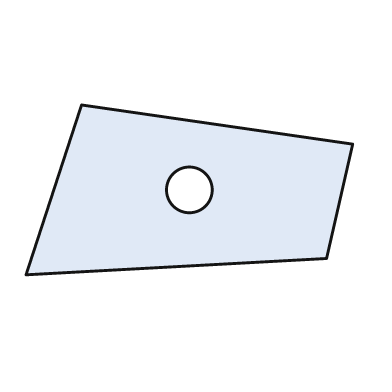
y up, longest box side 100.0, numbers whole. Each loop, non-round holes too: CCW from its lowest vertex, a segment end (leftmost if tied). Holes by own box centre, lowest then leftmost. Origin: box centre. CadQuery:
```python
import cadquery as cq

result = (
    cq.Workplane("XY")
    .moveTo(-50.0, -26.0)
    .lineTo(42.0, -21.0)
    .lineTo(50.0, 14.0)
    .lineTo(-33.0, 26.0)
    .close()
    .moveTo(0.0, 0.0)
    .circle(7.0)
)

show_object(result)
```